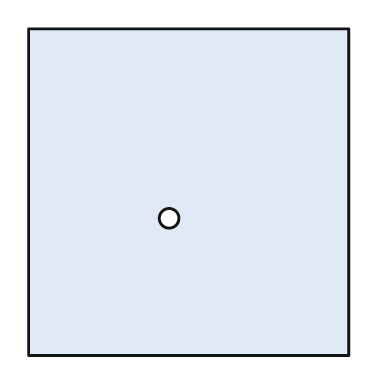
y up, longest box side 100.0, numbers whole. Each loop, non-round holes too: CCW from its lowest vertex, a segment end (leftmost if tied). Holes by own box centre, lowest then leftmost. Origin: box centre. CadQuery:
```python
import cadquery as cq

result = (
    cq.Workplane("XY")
    .moveTo(-49.0, -50.0)
    .lineTo(49.0, -50.0)
    .lineTo(49.0, 50.0)
    .lineTo(-49.0, 50.0)
    .close()
    .moveTo(-6.0, -8.0)
    .circle(3.0)
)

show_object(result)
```